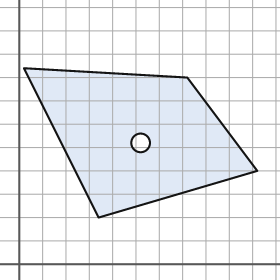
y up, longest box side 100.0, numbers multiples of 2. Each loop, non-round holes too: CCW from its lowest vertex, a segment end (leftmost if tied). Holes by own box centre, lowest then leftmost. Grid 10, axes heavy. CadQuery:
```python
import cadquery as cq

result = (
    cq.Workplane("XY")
    .moveTo(34.0, 20.0)
    .lineTo(102.0, 40.0)
    .lineTo(72.0, 80.0)
    .lineTo(2.0, 84.0)
    .close()
    .moveTo(52.0, 52.0)
    .circle(4.0)
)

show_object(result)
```